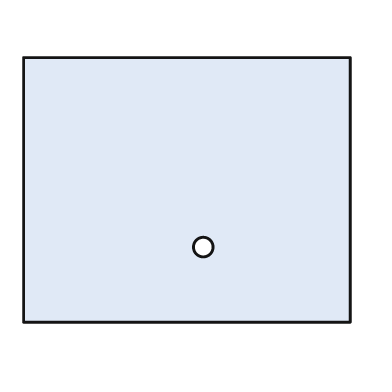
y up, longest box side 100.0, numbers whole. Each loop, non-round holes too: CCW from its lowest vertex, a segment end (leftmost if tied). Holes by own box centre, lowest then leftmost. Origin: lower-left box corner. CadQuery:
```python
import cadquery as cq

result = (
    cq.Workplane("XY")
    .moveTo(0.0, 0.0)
    .lineTo(100.0, 0.0)
    .lineTo(100.0, 81.0)
    .lineTo(0.0, 81.0)
    .close()
    .moveTo(55.0, 23.0)
    .circle(3.0)
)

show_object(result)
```